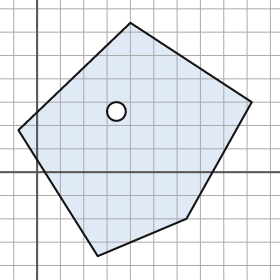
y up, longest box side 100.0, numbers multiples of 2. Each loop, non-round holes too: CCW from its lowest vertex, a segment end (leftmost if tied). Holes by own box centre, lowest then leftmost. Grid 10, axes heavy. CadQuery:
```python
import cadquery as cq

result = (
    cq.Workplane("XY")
    .moveTo(26.0, -36.0)
    .lineTo(64.0, -20.0)
    .lineTo(92.0, 30.0)
    .lineTo(40.0, 64.0)
    .lineTo(-8.0, 18.0)
    .close()
    .moveTo(34.0, 26.0)
    .circle(4.0)
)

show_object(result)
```